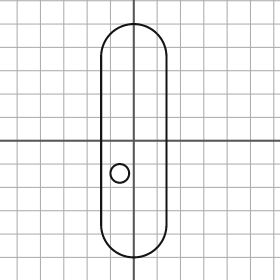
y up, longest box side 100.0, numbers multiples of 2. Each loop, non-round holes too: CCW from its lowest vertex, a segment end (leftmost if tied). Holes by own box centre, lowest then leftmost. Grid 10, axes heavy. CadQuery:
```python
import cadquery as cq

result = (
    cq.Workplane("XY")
    .moveTo(-14.0, -36.0)
    .threePointArc((0.0, -50.0), (14.0, -36.0))
    .lineTo(14.0, 36.0)
    .threePointArc((0.0, 50.0), (-14.0, 36.0))
    .close()
    .moveTo(-6.0, -14.0)
    .circle(4.0)
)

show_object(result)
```